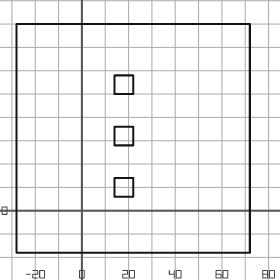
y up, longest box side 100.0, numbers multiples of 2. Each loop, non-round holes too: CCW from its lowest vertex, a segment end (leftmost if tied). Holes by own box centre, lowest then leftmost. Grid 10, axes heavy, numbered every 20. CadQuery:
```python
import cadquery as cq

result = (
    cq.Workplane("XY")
    .moveTo(-28.0, -18.0)
    .lineTo(72.0, -18.0)
    .lineTo(72.0, 80.0)
    .lineTo(-28.0, 80.0)
    .close()
    .moveTo(14.0, 6.0)
    .lineTo(22.0, 6.0)
    .lineTo(22.0, 14.0)
    .lineTo(14.0, 14.0)
    .close()
    .moveTo(14.0, 28.0)
    .lineTo(22.0, 28.0)
    .lineTo(22.0, 36.0)
    .lineTo(14.0, 36.0)
    .close()
    .moveTo(14.0, 50.0)
    .lineTo(22.0, 50.0)
    .lineTo(22.0, 58.0)
    .lineTo(14.0, 58.0)
    .close()
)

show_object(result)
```